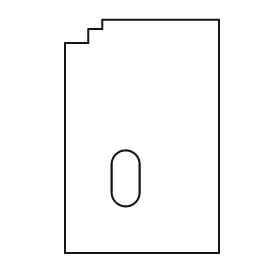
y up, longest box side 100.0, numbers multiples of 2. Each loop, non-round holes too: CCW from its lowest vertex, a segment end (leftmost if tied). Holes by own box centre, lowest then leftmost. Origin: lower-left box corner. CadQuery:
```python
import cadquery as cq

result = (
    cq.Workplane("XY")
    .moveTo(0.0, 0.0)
    .lineTo(66.0, 0.0)
    .lineTo(66.0, 100.0)
    .lineTo(16.0, 100.0)
    .lineTo(16.0, 96.0)
    .lineTo(10.0, 96.0)
    .lineTo(10.0, 90.0)
    .lineTo(0.0, 90.0)
    .close()
    .moveTo(20.0, 26.0)
    .threePointArc((26.0, 20.0), (32.0, 26.0))
    .lineTo(32.0, 38.0)
    .threePointArc((26.0, 44.0), (20.0, 38.0))
    .close()
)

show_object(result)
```